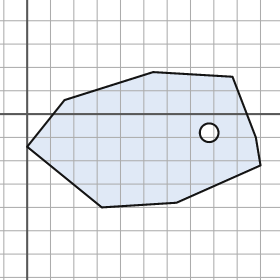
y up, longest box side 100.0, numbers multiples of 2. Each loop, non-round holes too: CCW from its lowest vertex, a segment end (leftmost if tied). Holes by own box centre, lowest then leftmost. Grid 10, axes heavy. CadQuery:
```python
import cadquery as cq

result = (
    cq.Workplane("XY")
    .moveTo(32.0, -40.0)
    .lineTo(64.0, -38.0)
    .lineTo(100.0, -22.0)
    .lineTo(98.0, -10.0)
    .lineTo(88.0, 16.0)
    .lineTo(54.0, 18.0)
    .lineTo(16.0, 6.0)
    .lineTo(0.0, -14.0)
    .close()
    .moveTo(78.0, -8.0)
    .circle(4.0)
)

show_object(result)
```